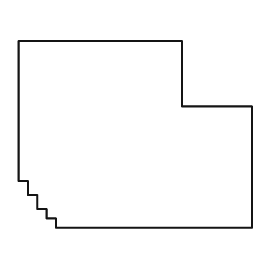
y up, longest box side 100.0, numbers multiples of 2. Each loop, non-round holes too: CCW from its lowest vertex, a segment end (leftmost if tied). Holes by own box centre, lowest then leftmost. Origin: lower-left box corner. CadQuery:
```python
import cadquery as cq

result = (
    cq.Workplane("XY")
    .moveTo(16.0, 0.0)
    .lineTo(100.0, 0.0)
    .lineTo(100.0, 52.0)
    .lineTo(70.0, 52.0)
    .lineTo(70.0, 80.0)
    .lineTo(0.0, 80.0)
    .lineTo(0.0, 20.0)
    .lineTo(4.0, 20.0)
    .lineTo(4.0, 14.0)
    .lineTo(8.0, 14.0)
    .lineTo(8.0, 8.0)
    .lineTo(12.0, 8.0)
    .lineTo(12.0, 4.0)
    .lineTo(16.0, 4.0)
    .close()
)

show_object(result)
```